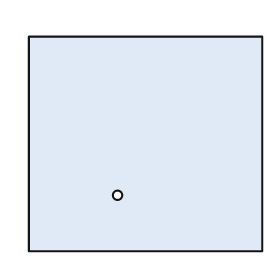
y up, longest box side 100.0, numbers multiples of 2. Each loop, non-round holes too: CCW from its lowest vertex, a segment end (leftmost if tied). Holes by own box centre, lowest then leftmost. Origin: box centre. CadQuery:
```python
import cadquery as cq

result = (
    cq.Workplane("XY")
    .moveTo(-50.0, -46.0)
    .lineTo(50.0, -46.0)
    .lineTo(50.0, 46.0)
    .lineTo(-50.0, 46.0)
    .close()
    .moveTo(-12.0, -22.0)
    .circle(2.0)
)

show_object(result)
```